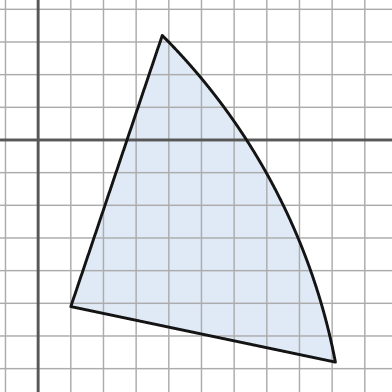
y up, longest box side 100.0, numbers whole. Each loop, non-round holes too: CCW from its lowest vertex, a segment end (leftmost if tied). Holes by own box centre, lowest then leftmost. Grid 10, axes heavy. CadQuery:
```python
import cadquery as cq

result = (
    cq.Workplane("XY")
    .moveTo(91.0, -68.0)
    .threePointArc((72.0, -14.0), (38.0, 32.0))
    .lineTo(10.0, -51.0)
    .close()
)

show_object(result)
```